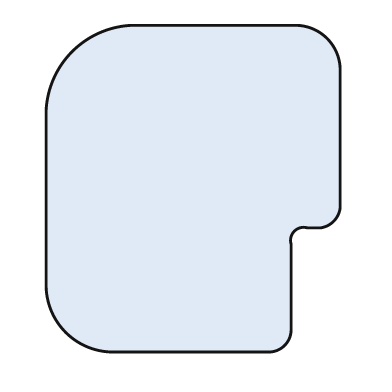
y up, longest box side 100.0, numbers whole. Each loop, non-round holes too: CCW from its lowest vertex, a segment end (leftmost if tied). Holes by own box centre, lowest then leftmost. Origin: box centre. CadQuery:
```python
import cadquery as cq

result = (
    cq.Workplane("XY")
    .moveTo(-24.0, -50.0)
    .lineTo(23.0, -50.0)
    .threePointArc((28.0, -48.0), (30.0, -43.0))
    .lineTo(30.0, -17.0)
    .threePointArc((31.0, -13.0), (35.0, -12.0))
    .lineTo(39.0, -12.0)
    .threePointArc((43.0, -10.0), (45.0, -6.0))
    .lineTo(45.0, 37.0)
    .threePointArc((41.0, 46.0), (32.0, 50.0))
    .lineTo(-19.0, 50.0)
    .threePointArc((-37.0, 42.0), (-45.0, 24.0))
    .lineTo(-45.0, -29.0)
    .threePointArc((-39.0, -44.0), (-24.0, -50.0))
    .close()
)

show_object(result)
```